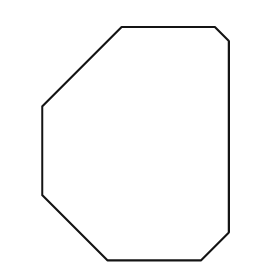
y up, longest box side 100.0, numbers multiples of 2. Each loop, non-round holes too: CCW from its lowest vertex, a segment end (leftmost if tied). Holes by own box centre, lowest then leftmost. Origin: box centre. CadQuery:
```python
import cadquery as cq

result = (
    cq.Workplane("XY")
    .moveTo(-12.0, -50.0)
    .lineTo(28.0, -50.0)
    .lineTo(40.0, -38.0)
    .lineTo(40.0, 44.0)
    .lineTo(34.0, 50.0)
    .lineTo(-6.0, 50.0)
    .lineTo(-40.0, 16.0)
    .lineTo(-40.0, -22.0)
    .close()
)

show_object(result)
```